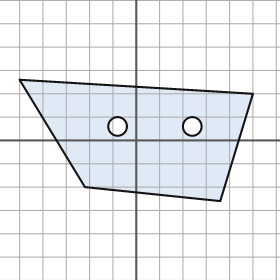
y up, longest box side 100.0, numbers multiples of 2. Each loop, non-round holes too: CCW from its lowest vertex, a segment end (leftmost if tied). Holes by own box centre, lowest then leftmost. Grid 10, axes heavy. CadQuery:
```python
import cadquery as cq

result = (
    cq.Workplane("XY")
    .moveTo(36.0, -26.0)
    .lineTo(50.0, 20.0)
    .lineTo(-50.0, 26.0)
    .lineTo(-22.0, -20.0)
    .close()
    .moveTo(-8.0, 6.0)
    .circle(4.0)
    .moveTo(24.0, 6.0)
    .circle(4.0)
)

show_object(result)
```